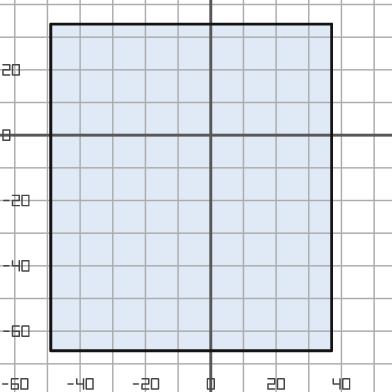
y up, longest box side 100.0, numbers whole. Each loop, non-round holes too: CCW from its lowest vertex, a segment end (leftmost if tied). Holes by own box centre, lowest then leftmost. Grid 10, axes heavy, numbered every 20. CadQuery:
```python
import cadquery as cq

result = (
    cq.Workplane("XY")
    .moveTo(-49.0, -66.0)
    .lineTo(37.0, -66.0)
    .lineTo(37.0, 34.0)
    .lineTo(-49.0, 34.0)
    .close()
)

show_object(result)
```